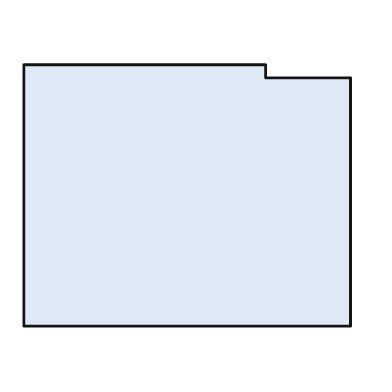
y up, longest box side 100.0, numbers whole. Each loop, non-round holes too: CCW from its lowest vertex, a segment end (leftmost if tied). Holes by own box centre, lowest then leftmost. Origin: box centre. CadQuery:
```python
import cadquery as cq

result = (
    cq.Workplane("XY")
    .moveTo(-50.0, -40.0)
    .lineTo(50.0, -40.0)
    .lineTo(50.0, 36.0)
    .lineTo(24.0, 36.0)
    .lineTo(24.0, 40.0)
    .lineTo(-50.0, 40.0)
    .close()
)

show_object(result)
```